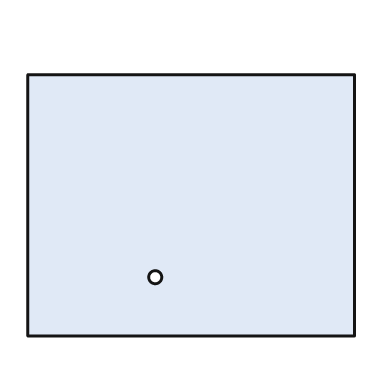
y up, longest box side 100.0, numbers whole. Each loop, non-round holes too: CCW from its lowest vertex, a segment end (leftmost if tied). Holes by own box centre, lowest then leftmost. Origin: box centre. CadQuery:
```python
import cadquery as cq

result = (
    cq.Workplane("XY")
    .moveTo(-50.0, -40.0)
    .lineTo(50.0, -40.0)
    .lineTo(50.0, 40.0)
    .lineTo(-50.0, 40.0)
    .close()
    .moveTo(-11.0, -22.0)
    .circle(2.0)
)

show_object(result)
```